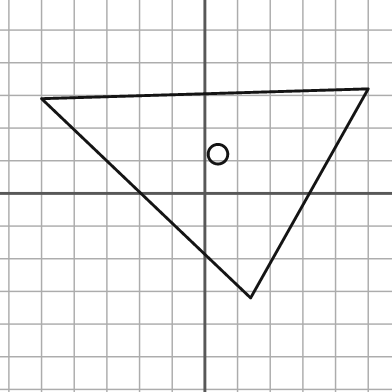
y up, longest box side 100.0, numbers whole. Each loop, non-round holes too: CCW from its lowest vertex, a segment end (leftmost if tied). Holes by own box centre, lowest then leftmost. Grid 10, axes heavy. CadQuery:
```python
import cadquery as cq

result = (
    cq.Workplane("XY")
    .moveTo(14.0, -32.0)
    .lineTo(50.0, 32.0)
    .lineTo(-50.0, 29.0)
    .close()
    .moveTo(4.0, 12.0)
    .circle(3.0)
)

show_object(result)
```